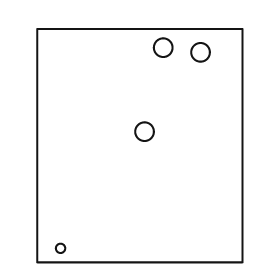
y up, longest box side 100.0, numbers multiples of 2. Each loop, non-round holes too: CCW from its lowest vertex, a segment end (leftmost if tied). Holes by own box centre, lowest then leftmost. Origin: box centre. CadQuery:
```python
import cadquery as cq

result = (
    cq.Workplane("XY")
    .moveTo(-44.0, -50.0)
    .lineTo(44.0, -50.0)
    .lineTo(44.0, 50.0)
    .lineTo(-44.0, 50.0)
    .close()
    .moveTo(-34.0, -44.0)
    .circle(2.0)
    .moveTo(2.0, 6.0)
    .circle(4.0)
    .moveTo(26.0, 40.0)
    .circle(4.0)
    .moveTo(10.0, 42.0)
    .circle(4.0)
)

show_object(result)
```